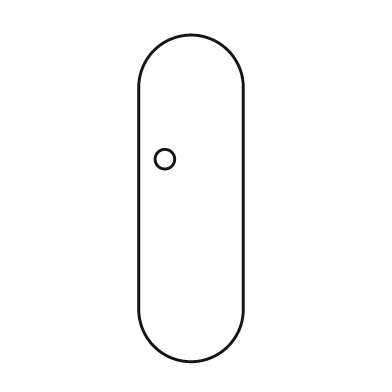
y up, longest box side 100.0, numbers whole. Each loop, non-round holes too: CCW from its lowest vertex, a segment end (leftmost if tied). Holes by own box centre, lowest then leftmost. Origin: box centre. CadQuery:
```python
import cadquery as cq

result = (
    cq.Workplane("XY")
    .moveTo(-16.0, -34.0)
    .threePointArc((0.0, -50.0), (16.0, -34.0))
    .lineTo(16.0, 34.0)
    .threePointArc((0.0, 50.0), (-16.0, 34.0))
    .close()
    .moveTo(-8.0, 12.0)
    .circle(3.0)
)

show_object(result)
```